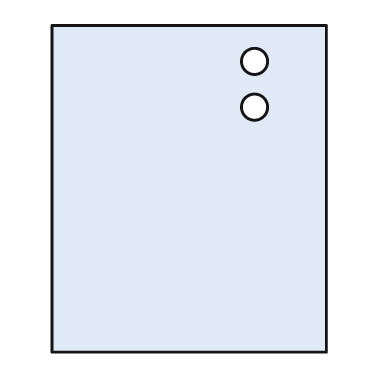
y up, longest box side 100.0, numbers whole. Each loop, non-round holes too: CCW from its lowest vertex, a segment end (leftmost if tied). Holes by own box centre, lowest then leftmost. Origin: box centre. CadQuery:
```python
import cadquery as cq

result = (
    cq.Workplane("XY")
    .moveTo(-42.0, -50.0)
    .lineTo(42.0, -50.0)
    .lineTo(42.0, 50.0)
    .lineTo(-42.0, 50.0)
    .close()
    .moveTo(20.0, 25.0)
    .circle(4.0)
    .moveTo(20.0, 39.0)
    .circle(4.0)
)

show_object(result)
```